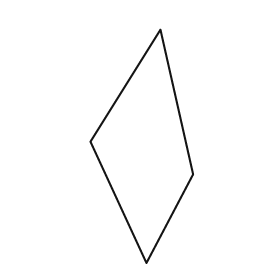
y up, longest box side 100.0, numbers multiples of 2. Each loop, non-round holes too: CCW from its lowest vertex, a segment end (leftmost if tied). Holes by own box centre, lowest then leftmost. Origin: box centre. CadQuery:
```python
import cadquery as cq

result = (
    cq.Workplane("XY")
    .moveTo(2.0, -50.0)
    .lineTo(22.0, -12.0)
    .lineTo(8.0, 50.0)
    .lineTo(-22.0, 2.0)
    .close()
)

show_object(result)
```